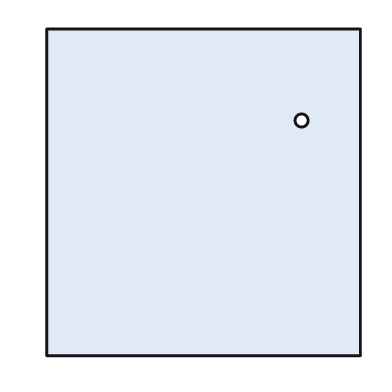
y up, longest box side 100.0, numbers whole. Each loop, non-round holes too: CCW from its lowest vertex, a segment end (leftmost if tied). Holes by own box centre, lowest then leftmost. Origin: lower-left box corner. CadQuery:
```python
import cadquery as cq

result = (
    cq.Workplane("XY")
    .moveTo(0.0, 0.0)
    .lineTo(96.0, 0.0)
    .lineTo(96.0, 100.0)
    .lineTo(0.0, 100.0)
    .close()
    .moveTo(78.0, 72.0)
    .circle(2.0)
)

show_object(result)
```